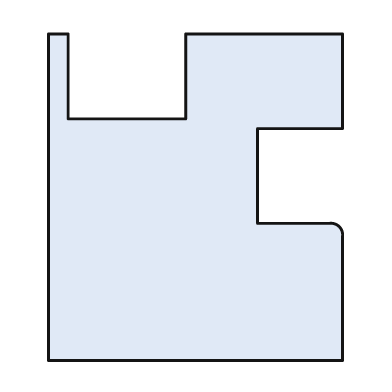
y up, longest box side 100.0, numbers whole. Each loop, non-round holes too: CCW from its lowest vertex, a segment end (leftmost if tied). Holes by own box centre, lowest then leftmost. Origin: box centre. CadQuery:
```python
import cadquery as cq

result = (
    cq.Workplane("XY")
    .moveTo(-45.0, -50.0)
    .lineTo(45.0, -50.0)
    .lineTo(45.0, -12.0)
    .threePointArc((44.0, -9.0), (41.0, -8.0))
    .lineTo(19.0, -8.0)
    .lineTo(19.0, 21.0)
    .lineTo(45.0, 21.0)
    .lineTo(45.0, 50.0)
    .lineTo(-3.0, 50.0)
    .lineTo(-3.0, 24.0)
    .lineTo(-39.0, 24.0)
    .lineTo(-39.0, 50.0)
    .lineTo(-45.0, 50.0)
    .close()
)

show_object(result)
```